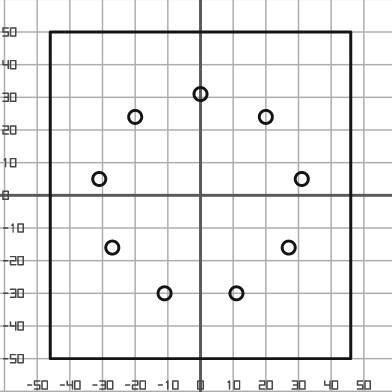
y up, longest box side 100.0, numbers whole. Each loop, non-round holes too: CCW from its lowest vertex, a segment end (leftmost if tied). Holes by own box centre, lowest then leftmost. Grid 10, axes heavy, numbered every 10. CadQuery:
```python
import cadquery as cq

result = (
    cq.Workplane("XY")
    .moveTo(-46.0, -50.0)
    .lineTo(46.0, -50.0)
    .lineTo(46.0, 50.0)
    .lineTo(-46.0, 50.0)
    .close()
    .moveTo(-11.0, -30.0)
    .circle(2.0)
    .moveTo(11.0, -30.0)
    .circle(2.0)
    .moveTo(-27.0, -16.0)
    .circle(2.0)
    .moveTo(27.0, -16.0)
    .circle(2.0)
    .moveTo(-31.0, 5.0)
    .circle(2.0)
    .moveTo(31.0, 5.0)
    .circle(2.0)
    .moveTo(-20.0, 24.0)
    .circle(2.0)
    .moveTo(20.0, 24.0)
    .circle(2.0)
    .moveTo(0.0, 31.0)
    .circle(2.0)
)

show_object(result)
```